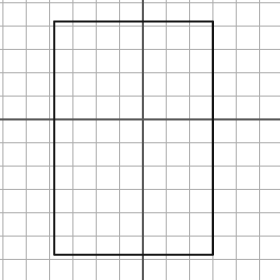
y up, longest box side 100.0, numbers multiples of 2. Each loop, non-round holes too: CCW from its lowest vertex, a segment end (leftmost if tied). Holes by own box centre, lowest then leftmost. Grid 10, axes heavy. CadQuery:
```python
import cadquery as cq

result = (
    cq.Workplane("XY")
    .moveTo(-38.0, -58.0)
    .lineTo(30.0, -58.0)
    .lineTo(30.0, 42.0)
    .lineTo(-38.0, 42.0)
    .close()
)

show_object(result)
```